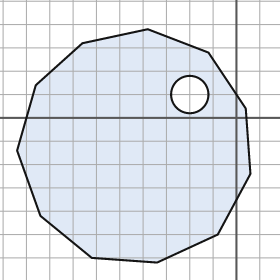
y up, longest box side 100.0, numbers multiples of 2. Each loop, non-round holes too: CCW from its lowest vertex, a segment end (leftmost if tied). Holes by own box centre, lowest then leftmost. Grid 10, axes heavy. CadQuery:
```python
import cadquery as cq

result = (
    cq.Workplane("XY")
    .moveTo(-34.0, -62.0)
    .lineTo(-8.0, -50.0)
    .lineTo(6.0, -24.0)
    .lineTo(4.0, 4.0)
    .lineTo(-12.0, 28.0)
    .lineTo(-38.0, 38.0)
    .lineTo(-66.0, 32.0)
    .lineTo(-86.0, 14.0)
    .lineTo(-94.0, -14.0)
    .lineTo(-84.0, -42.0)
    .lineTo(-62.0, -60.0)
    .close()
    .moveTo(-20.0, 10.0)
    .circle(8.0)
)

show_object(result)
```